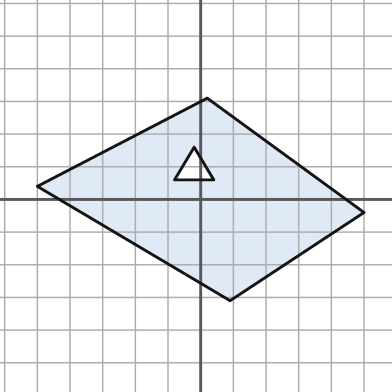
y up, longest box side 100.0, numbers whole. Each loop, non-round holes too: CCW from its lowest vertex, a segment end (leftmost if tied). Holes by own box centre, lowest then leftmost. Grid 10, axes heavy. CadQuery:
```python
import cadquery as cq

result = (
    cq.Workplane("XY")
    .moveTo(9.0, -31.0)
    .lineTo(50.0, -4.0)
    .lineTo(2.0, 31.0)
    .lineTo(-50.0, 4.0)
    .close()
    .moveTo(-8.0, 6.0)
    .lineTo(4.0, 6.0)
    .lineTo(-2.0, 16.0)
    .close()
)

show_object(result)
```